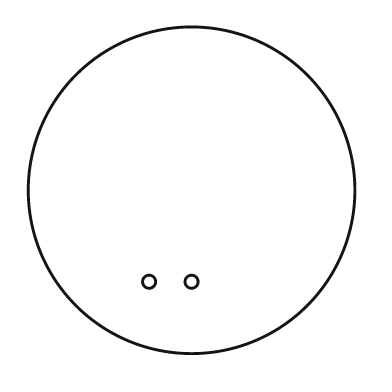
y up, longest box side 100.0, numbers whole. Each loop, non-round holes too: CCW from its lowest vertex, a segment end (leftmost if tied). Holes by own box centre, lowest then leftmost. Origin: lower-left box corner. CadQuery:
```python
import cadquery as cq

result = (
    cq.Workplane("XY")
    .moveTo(50.0, 50.0)
    .circle(50.0)
    .moveTo(37.0, 22.0)
    .circle(2.0)
    .moveTo(50.0, 22.0)
    .circle(2.0)
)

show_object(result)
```